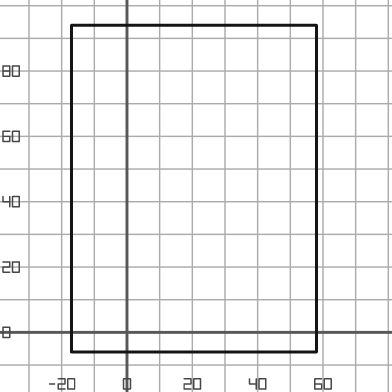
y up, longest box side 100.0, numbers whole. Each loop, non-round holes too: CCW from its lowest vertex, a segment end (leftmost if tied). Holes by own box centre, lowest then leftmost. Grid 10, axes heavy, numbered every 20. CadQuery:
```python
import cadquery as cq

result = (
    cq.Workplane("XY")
    .moveTo(-17.0, -6.0)
    .lineTo(58.0, -6.0)
    .lineTo(58.0, 94.0)
    .lineTo(-17.0, 94.0)
    .close()
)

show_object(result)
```